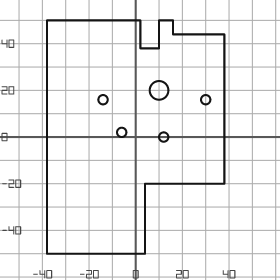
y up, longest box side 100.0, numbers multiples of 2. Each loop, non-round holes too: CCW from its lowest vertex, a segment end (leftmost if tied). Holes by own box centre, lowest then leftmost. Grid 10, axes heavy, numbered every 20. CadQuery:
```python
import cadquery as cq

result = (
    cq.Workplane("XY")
    .moveTo(-38.0, -50.0)
    .lineTo(4.0, -50.0)
    .lineTo(4.0, -20.0)
    .lineTo(38.0, -20.0)
    .lineTo(38.0, 44.0)
    .lineTo(16.0, 44.0)
    .lineTo(16.0, 50.0)
    .lineTo(10.0, 50.0)
    .lineTo(10.0, 38.0)
    .lineTo(2.0, 38.0)
    .lineTo(2.0, 50.0)
    .lineTo(-38.0, 50.0)
    .close()
    .moveTo(12.0, 0.0)
    .circle(2.0)
    .moveTo(-6.0, 2.0)
    .circle(2.0)
    .moveTo(-14.0, 16.0)
    .circle(2.0)
    .moveTo(30.0, 16.0)
    .circle(2.0)
    .moveTo(10.0, 20.0)
    .circle(4.0)
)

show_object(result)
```